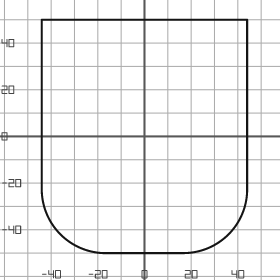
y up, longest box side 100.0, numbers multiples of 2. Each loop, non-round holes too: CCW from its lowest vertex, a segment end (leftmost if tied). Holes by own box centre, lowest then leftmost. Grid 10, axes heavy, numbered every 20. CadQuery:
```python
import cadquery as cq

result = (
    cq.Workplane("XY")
    .moveTo(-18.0, -50.0)
    .lineTo(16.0, -50.0)
    .threePointArc((36.0, -42.0), (44.0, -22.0))
    .lineTo(44.0, 50.0)
    .lineTo(-44.0, 50.0)
    .lineTo(-44.0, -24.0)
    .threePointArc((-36.0, -42.0), (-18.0, -50.0))
    .close()
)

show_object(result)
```